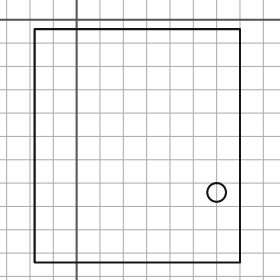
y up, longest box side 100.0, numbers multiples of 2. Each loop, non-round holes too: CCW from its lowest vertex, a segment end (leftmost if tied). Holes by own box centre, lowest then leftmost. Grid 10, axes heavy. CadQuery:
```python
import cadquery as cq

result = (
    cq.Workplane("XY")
    .moveTo(-18.0, -104.0)
    .lineTo(70.0, -104.0)
    .lineTo(70.0, -4.0)
    .lineTo(-18.0, -4.0)
    .close()
    .moveTo(60.0, -74.0)
    .circle(4.0)
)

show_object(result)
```